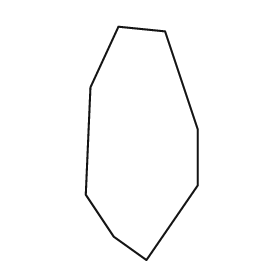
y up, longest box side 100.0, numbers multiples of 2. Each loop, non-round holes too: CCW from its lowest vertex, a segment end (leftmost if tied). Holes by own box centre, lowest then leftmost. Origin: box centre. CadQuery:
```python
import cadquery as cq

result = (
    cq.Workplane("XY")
    .moveTo(2.0, -50.0)
    .lineTo(24.0, -18.0)
    .lineTo(24.0, 6.0)
    .lineTo(10.0, 48.0)
    .lineTo(-10.0, 50.0)
    .lineTo(-22.0, 24.0)
    .lineTo(-24.0, -22.0)
    .lineTo(-12.0, -40.0)
    .close()
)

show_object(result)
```